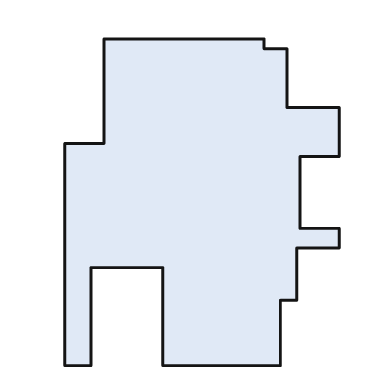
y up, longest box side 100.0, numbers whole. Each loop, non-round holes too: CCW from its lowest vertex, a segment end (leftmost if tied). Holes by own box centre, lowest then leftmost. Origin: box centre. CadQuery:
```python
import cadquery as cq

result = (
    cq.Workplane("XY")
    .moveTo(-42.0, -50.0)
    .lineTo(-34.0, -50.0)
    .lineTo(-34.0, -20.0)
    .lineTo(-12.0, -20.0)
    .lineTo(-12.0, -50.0)
    .lineTo(24.0, -50.0)
    .lineTo(24.0, -30.0)
    .lineTo(29.0, -30.0)
    .lineTo(29.0, -14.0)
    .lineTo(42.0, -14.0)
    .lineTo(42.0, -8.0)
    .lineTo(30.0, -8.0)
    .lineTo(30.0, 14.0)
    .lineTo(42.0, 14.0)
    .lineTo(42.0, 29.0)
    .lineTo(26.0, 29.0)
    .lineTo(26.0, 47.0)
    .lineTo(19.0, 47.0)
    .lineTo(19.0, 50.0)
    .lineTo(-30.0, 50.0)
    .lineTo(-30.0, 18.0)
    .lineTo(-42.0, 18.0)
    .close()
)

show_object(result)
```